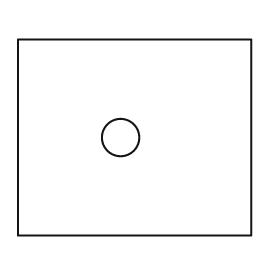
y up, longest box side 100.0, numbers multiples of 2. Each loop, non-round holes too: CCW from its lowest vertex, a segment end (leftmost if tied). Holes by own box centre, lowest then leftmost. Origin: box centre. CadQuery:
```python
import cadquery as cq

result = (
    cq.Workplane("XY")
    .moveTo(-50.0, -42.0)
    .lineTo(50.0, -42.0)
    .lineTo(50.0, 42.0)
    .lineTo(-50.0, 42.0)
    .close()
    .moveTo(-6.0, 0.0)
    .circle(8.0)
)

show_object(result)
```